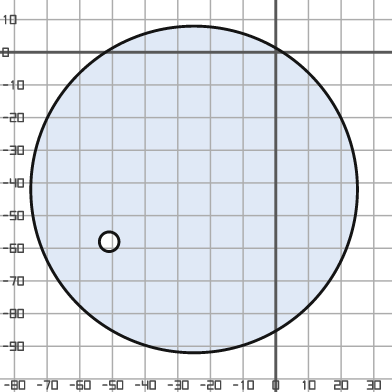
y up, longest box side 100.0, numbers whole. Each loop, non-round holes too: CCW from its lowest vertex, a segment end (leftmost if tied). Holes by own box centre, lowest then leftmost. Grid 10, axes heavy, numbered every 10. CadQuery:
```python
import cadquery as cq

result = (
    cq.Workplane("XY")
    .moveTo(-25.0, -42.0)
    .circle(50.0)
    .moveTo(-51.0, -58.0)
    .circle(3.0)
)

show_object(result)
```